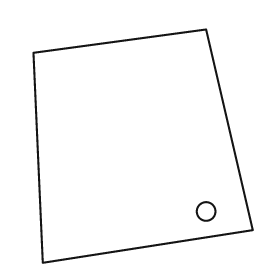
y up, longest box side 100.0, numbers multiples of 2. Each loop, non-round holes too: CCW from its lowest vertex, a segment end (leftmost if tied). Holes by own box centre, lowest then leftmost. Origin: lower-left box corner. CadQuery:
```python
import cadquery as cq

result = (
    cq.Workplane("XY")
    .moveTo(4.0, 0.0)
    .lineTo(94.0, 14.0)
    .lineTo(74.0, 100.0)
    .lineTo(0.0, 90.0)
    .close()
    .moveTo(74.0, 22.0)
    .circle(4.0)
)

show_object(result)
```